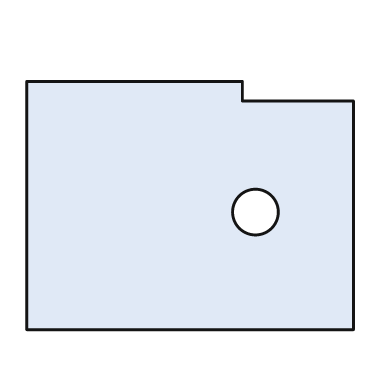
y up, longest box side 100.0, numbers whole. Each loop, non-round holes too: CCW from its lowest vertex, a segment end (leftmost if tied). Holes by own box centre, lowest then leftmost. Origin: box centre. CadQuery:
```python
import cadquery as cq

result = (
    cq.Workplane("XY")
    .moveTo(-50.0, -38.0)
    .lineTo(50.0, -38.0)
    .lineTo(50.0, 32.0)
    .lineTo(16.0, 32.0)
    .lineTo(16.0, 38.0)
    .lineTo(-50.0, 38.0)
    .close()
    .moveTo(20.0, -2.0)
    .circle(7.0)
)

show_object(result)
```